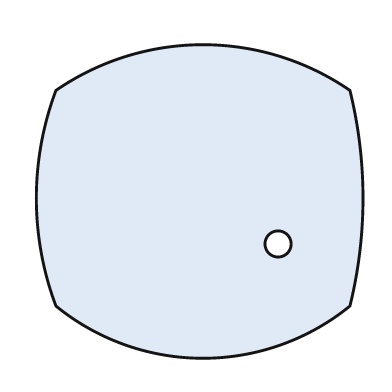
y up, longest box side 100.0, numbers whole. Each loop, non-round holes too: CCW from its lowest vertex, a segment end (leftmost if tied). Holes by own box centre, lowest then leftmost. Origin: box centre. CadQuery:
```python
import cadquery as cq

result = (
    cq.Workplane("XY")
    .moveTo(-44.0, -32.0)
    .threePointArc((1.0, -48.0), (46.0, -32.0))
    .threePointArc((50.0, 1.0), (46.0, 34.0))
    .threePointArc((1.0, 48.0), (-44.0, 34.0))
    .threePointArc((-50.0, 1.0), (-44.0, -32.0))
    .close()
    .moveTo(24.0, -13.0)
    .circle(4.0)
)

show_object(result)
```